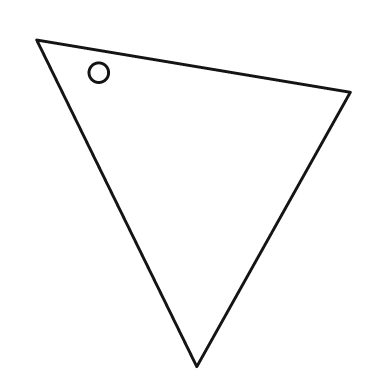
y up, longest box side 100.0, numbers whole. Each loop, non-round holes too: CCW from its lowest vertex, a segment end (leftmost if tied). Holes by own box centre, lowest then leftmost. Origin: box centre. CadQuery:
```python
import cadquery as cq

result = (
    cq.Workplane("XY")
    .moveTo(1.0, -50.0)
    .lineTo(48.0, 34.0)
    .lineTo(-48.0, 50.0)
    .close()
    .moveTo(-29.0, 40.0)
    .circle(3.0)
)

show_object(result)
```